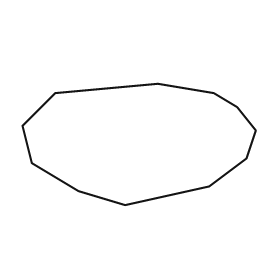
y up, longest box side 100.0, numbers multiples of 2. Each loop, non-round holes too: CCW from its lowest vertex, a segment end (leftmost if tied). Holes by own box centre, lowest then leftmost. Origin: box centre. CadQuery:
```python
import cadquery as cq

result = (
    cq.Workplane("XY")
    .moveTo(-6.0, -26.0)
    .lineTo(30.0, -18.0)
    .lineTo(46.0, -6.0)
    .lineTo(50.0, 6.0)
    .lineTo(42.0, 16.0)
    .lineTo(32.0, 22.0)
    .lineTo(8.0, 26.0)
    .lineTo(-36.0, 22.0)
    .lineTo(-50.0, 8.0)
    .lineTo(-46.0, -8.0)
    .lineTo(-26.0, -20.0)
    .close()
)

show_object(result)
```